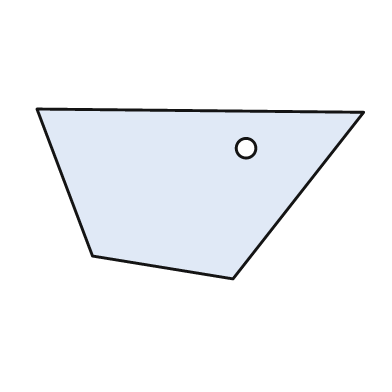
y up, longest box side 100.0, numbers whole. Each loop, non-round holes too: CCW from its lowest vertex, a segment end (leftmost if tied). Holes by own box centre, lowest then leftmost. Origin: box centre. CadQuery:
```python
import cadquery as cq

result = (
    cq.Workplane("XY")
    .moveTo(10.0, -26.0)
    .lineTo(50.0, 25.0)
    .lineTo(-50.0, 26.0)
    .lineTo(-33.0, -19.0)
    .close()
    .moveTo(14.0, 14.0)
    .circle(3.0)
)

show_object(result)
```